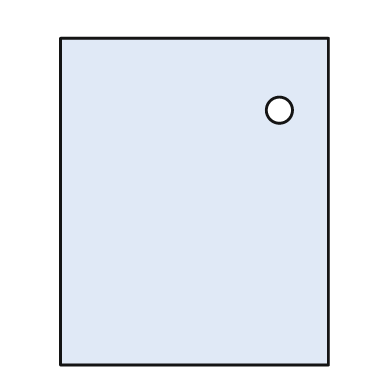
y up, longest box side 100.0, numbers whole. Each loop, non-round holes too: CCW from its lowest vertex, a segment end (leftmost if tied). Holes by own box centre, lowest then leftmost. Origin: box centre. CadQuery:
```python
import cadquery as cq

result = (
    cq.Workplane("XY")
    .moveTo(-41.0, -50.0)
    .lineTo(41.0, -50.0)
    .lineTo(41.0, 50.0)
    .lineTo(-41.0, 50.0)
    .close()
    .moveTo(26.0, 28.0)
    .circle(4.0)
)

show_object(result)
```